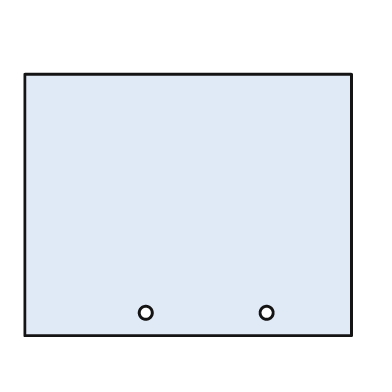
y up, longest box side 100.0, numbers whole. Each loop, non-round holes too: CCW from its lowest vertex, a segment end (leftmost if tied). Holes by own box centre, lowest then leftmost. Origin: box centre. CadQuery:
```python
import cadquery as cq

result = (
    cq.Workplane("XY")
    .moveTo(-50.0, -40.0)
    .lineTo(50.0, -40.0)
    .lineTo(50.0, 40.0)
    .lineTo(-50.0, 40.0)
    .close()
    .moveTo(-13.0, -33.0)
    .circle(2.0)
    .moveTo(24.0, -33.0)
    .circle(2.0)
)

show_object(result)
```